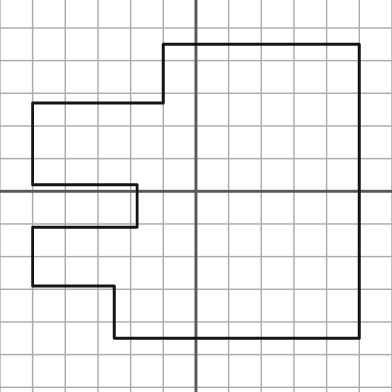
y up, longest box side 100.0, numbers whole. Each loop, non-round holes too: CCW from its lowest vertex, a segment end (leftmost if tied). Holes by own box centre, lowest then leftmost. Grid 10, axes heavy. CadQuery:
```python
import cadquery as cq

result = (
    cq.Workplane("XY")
    .moveTo(-25.0, -45.0)
    .lineTo(50.0, -45.0)
    .lineTo(50.0, 45.0)
    .lineTo(-10.0, 45.0)
    .lineTo(-10.0, 27.0)
    .lineTo(-50.0, 27.0)
    .lineTo(-50.0, 2.0)
    .lineTo(-18.0, 2.0)
    .lineTo(-18.0, -11.0)
    .lineTo(-50.0, -11.0)
    .lineTo(-50.0, -29.0)
    .lineTo(-25.0, -29.0)
    .close()
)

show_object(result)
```